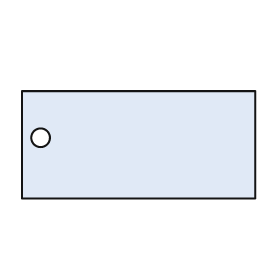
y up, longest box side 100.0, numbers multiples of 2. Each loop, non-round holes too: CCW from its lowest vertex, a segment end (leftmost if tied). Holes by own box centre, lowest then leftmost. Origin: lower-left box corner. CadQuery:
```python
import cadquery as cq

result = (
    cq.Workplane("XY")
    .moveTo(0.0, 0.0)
    .lineTo(100.0, 0.0)
    .lineTo(100.0, 46.0)
    .lineTo(0.0, 46.0)
    .close()
    .moveTo(8.0, 26.0)
    .circle(4.0)
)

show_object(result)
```